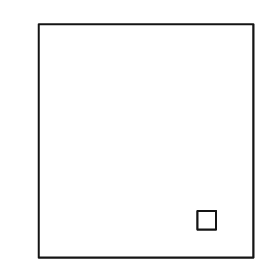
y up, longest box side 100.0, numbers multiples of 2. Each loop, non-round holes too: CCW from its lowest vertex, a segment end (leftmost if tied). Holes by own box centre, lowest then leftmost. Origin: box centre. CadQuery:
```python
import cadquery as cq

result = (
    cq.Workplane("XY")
    .moveTo(-46.0, -50.0)
    .lineTo(46.0, -50.0)
    .lineTo(46.0, 50.0)
    .lineTo(-46.0, 50.0)
    .close()
    .moveTo(22.0, -38.0)
    .lineTo(30.0, -38.0)
    .lineTo(30.0, -30.0)
    .lineTo(22.0, -30.0)
    .close()
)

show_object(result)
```